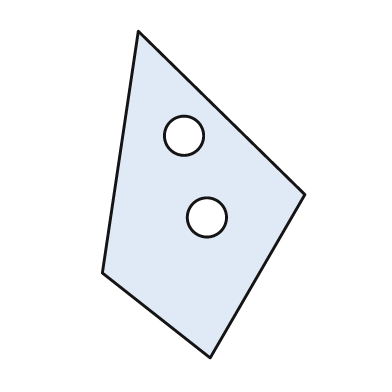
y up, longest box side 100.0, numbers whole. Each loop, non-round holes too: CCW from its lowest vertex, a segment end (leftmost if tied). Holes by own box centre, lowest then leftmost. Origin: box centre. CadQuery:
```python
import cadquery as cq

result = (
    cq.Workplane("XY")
    .moveTo(2.0, -50.0)
    .lineTo(31.0, 0.0)
    .lineTo(-20.0, 50.0)
    .lineTo(-31.0, -24.0)
    .close()
    .moveTo(1.0, -7.0)
    .circle(6.0)
    .moveTo(-6.0, 18.0)
    .circle(6.0)
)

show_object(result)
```